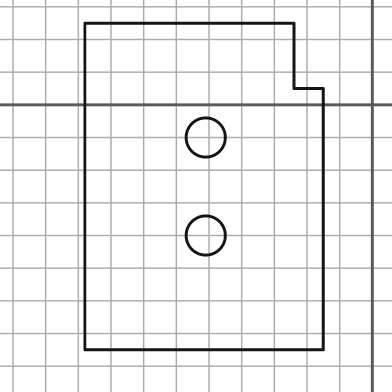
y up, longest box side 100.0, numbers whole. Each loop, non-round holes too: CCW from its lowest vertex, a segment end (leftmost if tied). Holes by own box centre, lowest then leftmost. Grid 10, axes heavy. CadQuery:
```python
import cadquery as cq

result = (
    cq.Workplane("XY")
    .moveTo(-88.0, -75.0)
    .lineTo(-15.0, -75.0)
    .lineTo(-15.0, 5.0)
    .lineTo(-24.0, 5.0)
    .lineTo(-24.0, 25.0)
    .lineTo(-88.0, 25.0)
    .close()
    .moveTo(-51.0, -40.0)
    .circle(6.0)
    .moveTo(-51.0, -10.0)
    .circle(6.0)
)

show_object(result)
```